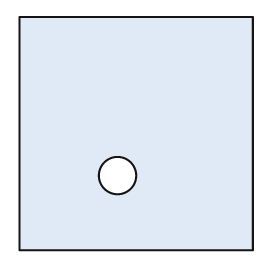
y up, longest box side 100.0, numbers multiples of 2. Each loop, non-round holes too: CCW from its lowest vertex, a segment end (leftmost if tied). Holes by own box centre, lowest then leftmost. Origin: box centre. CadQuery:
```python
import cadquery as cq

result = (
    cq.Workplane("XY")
    .moveTo(-50.0, -50.0)
    .lineTo(50.0, -50.0)
    .lineTo(50.0, 50.0)
    .lineTo(-50.0, 50.0)
    .close()
    .moveTo(-8.0, -18.0)
    .circle(8.0)
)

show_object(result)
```